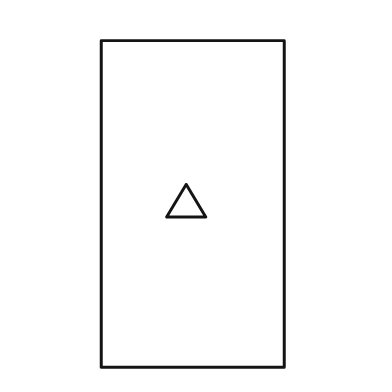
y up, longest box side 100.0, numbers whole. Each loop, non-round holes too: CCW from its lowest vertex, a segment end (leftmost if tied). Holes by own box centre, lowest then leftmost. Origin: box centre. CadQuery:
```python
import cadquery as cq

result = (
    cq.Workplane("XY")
    .moveTo(-28.0, -50.0)
    .lineTo(28.0, -50.0)
    .lineTo(28.0, 50.0)
    .lineTo(-28.0, 50.0)
    .close()
    .moveTo(-8.0, -4.0)
    .lineTo(4.0, -4.0)
    .lineTo(-2.0, 6.0)
    .close()
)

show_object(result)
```